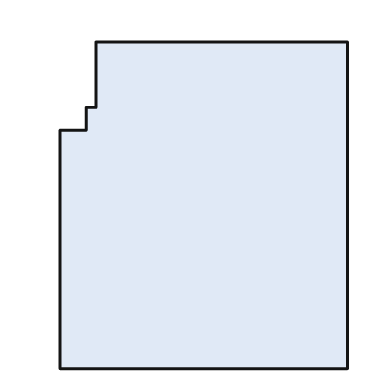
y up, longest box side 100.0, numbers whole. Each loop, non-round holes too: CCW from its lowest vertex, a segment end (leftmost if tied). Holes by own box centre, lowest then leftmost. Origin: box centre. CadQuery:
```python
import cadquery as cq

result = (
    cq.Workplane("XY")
    .moveTo(-44.0, -50.0)
    .lineTo(44.0, -50.0)
    .lineTo(44.0, 50.0)
    .lineTo(-33.0, 50.0)
    .lineTo(-33.0, 30.0)
    .lineTo(-36.0, 30.0)
    .lineTo(-36.0, 23.0)
    .lineTo(-44.0, 23.0)
    .close()
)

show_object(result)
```